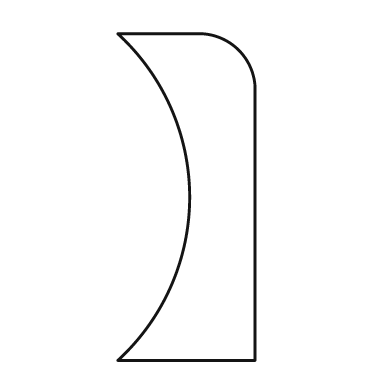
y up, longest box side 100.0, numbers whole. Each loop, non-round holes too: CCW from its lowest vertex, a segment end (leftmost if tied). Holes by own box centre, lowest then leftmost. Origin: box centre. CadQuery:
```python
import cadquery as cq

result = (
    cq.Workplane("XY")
    .moveTo(-21.0, -50.0)
    .lineTo(21.0, -50.0)
    .lineTo(21.0, 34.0)
    .threePointArc((16.0, 45.0), (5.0, 50.0))
    .lineTo(-21.0, 50.0)
    .threePointArc((1.0, 0.0), (-21.0, -50.0))
    .close()
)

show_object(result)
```